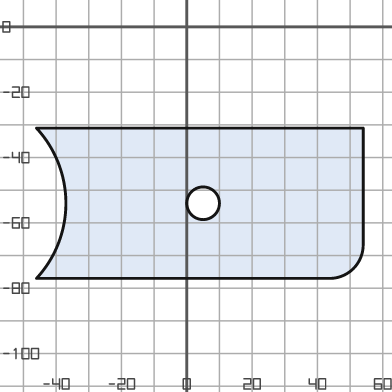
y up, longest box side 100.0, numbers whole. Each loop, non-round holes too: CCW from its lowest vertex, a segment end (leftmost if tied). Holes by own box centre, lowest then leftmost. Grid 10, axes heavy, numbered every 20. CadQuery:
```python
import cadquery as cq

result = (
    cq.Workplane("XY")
    .moveTo(-46.0, -77.0)
    .lineTo(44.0, -77.0)
    .threePointArc((51.0, -74.0), (54.0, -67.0))
    .lineTo(54.0, -31.0)
    .lineTo(-46.0, -31.0)
    .threePointArc((-37.0, -54.0), (-46.0, -77.0))
    .close()
    .moveTo(5.0, -54.0)
    .circle(5.0)
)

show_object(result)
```